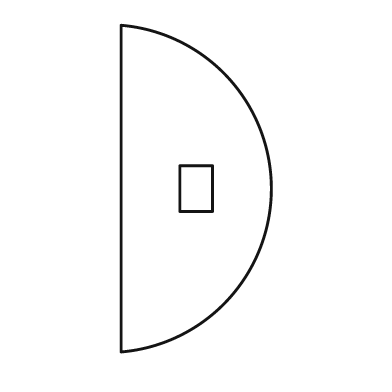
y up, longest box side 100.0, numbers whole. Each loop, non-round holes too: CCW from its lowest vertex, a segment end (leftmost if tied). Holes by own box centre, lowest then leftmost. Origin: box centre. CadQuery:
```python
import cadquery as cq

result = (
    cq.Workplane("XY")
    .moveTo(-23.0, -50.0)
    .threePointArc((23.0, 0.0), (-23.0, 50.0))
    .close()
    .moveTo(-5.0, -7.0)
    .lineTo(5.0, -7.0)
    .lineTo(5.0, 7.0)
    .lineTo(-5.0, 7.0)
    .close()
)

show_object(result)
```